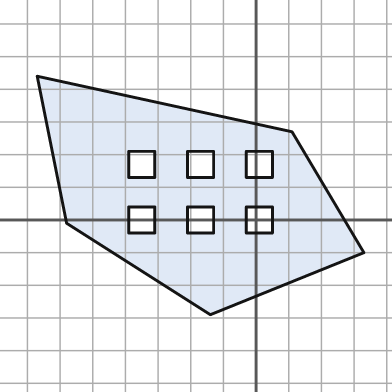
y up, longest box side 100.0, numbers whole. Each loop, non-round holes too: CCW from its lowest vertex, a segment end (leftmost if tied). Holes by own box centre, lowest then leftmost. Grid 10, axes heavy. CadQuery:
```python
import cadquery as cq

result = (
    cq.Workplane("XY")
    .moveTo(-14.0, -29.0)
    .lineTo(33.0, -10.0)
    .lineTo(11.0, 27.0)
    .lineTo(-67.0, 44.0)
    .lineTo(-58.0, -1.0)
    .close()
    .moveTo(-39.0, -4.0)
    .lineTo(-31.0, -4.0)
    .lineTo(-31.0, 4.0)
    .lineTo(-39.0, 4.0)
    .close()
    .moveTo(-21.0, -4.0)
    .lineTo(-13.0, -4.0)
    .lineTo(-13.0, 4.0)
    .lineTo(-21.0, 4.0)
    .close()
    .moveTo(-3.0, -4.0)
    .lineTo(5.0, -4.0)
    .lineTo(5.0, 4.0)
    .lineTo(-3.0, 4.0)
    .close()
    .moveTo(-39.0, 13.0)
    .lineTo(-31.0, 13.0)
    .lineTo(-31.0, 21.0)
    .lineTo(-39.0, 21.0)
    .close()
    .moveTo(-21.0, 13.0)
    .lineTo(-13.0, 13.0)
    .lineTo(-13.0, 21.0)
    .lineTo(-21.0, 21.0)
    .close()
    .moveTo(-3.0, 13.0)
    .lineTo(5.0, 13.0)
    .lineTo(5.0, 21.0)
    .lineTo(-3.0, 21.0)
    .close()
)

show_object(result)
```